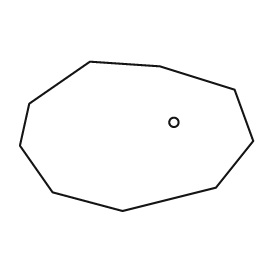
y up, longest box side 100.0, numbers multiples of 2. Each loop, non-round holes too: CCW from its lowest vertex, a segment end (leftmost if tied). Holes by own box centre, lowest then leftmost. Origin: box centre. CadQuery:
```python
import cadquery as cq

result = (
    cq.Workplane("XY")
    .moveTo(-6.0, -32.0)
    .lineTo(34.0, -22.0)
    .lineTo(50.0, -2.0)
    .lineTo(42.0, 20.0)
    .lineTo(10.0, 30.0)
    .lineTo(-20.0, 32.0)
    .lineTo(-46.0, 14.0)
    .lineTo(-50.0, -4.0)
    .lineTo(-36.0, -24.0)
    .close()
    .moveTo(16.0, 6.0)
    .circle(2.0)
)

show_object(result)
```